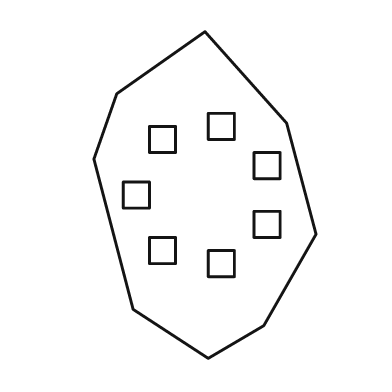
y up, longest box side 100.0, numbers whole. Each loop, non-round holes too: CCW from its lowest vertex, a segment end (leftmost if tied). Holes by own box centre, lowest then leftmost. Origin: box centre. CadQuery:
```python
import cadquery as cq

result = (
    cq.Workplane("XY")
    .moveTo(1.0, -50.0)
    .lineTo(18.0, -40.0)
    .lineTo(34.0, -12.0)
    .lineTo(25.0, 22.0)
    .lineTo(0.0, 50.0)
    .lineTo(-27.0, 31.0)
    .lineTo(-34.0, 11.0)
    .lineTo(-22.0, -35.0)
    .close()
    .moveTo(1.0, -25.0)
    .lineTo(9.0, -25.0)
    .lineTo(9.0, -17.0)
    .lineTo(1.0, -17.0)
    .close()
    .moveTo(-17.0, -21.0)
    .lineTo(-9.0, -21.0)
    .lineTo(-9.0, -13.0)
    .lineTo(-17.0, -13.0)
    .close()
    .moveTo(15.0, -13.0)
    .lineTo(23.0, -13.0)
    .lineTo(23.0, -5.0)
    .lineTo(15.0, -5.0)
    .close()
    .moveTo(-25.0, -4.0)
    .lineTo(-17.0, -4.0)
    .lineTo(-17.0, 4.0)
    .lineTo(-25.0, 4.0)
    .close()
    .moveTo(15.0, 5.0)
    .lineTo(23.0, 5.0)
    .lineTo(23.0, 13.0)
    .lineTo(15.0, 13.0)
    .close()
    .moveTo(-17.0, 13.0)
    .lineTo(-9.0, 13.0)
    .lineTo(-9.0, 21.0)
    .lineTo(-17.0, 21.0)
    .close()
    .moveTo(1.0, 17.0)
    .lineTo(9.0, 17.0)
    .lineTo(9.0, 25.0)
    .lineTo(1.0, 25.0)
    .close()
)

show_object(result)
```